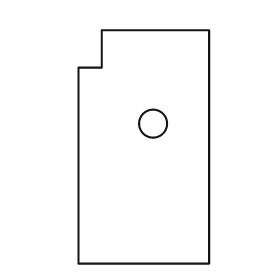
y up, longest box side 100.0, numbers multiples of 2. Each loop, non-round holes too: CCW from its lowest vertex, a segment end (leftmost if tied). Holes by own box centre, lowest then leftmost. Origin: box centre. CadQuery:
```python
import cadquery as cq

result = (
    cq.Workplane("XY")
    .moveTo(-28.0, -50.0)
    .lineTo(28.0, -50.0)
    .lineTo(28.0, 50.0)
    .lineTo(-18.0, 50.0)
    .lineTo(-18.0, 34.0)
    .lineTo(-28.0, 34.0)
    .close()
    .moveTo(4.0, 10.0)
    .circle(6.0)
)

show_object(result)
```